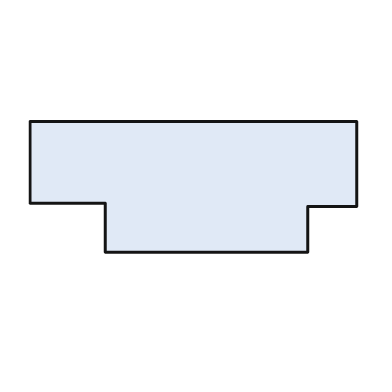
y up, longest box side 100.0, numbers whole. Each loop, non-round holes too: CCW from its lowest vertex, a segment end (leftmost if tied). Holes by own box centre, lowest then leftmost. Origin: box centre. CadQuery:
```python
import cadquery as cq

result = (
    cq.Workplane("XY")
    .moveTo(-27.0, -20.0)
    .lineTo(35.0, -20.0)
    .lineTo(35.0, -6.0)
    .lineTo(50.0, -6.0)
    .lineTo(50.0, 20.0)
    .lineTo(-50.0, 20.0)
    .lineTo(-50.0, -5.0)
    .lineTo(-27.0, -5.0)
    .close()
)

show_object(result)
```